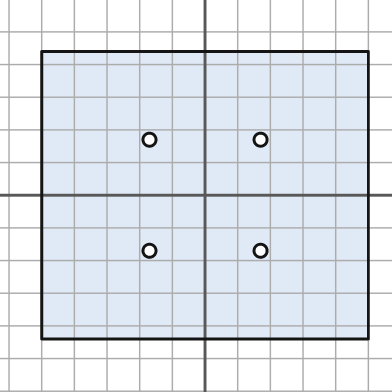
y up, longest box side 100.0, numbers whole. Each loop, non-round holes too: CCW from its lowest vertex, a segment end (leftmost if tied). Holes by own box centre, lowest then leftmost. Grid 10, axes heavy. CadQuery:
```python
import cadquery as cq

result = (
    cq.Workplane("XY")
    .moveTo(-50.0, -44.0)
    .lineTo(50.0, -44.0)
    .lineTo(50.0, 44.0)
    .lineTo(-50.0, 44.0)
    .close()
    .moveTo(-17.0, -17.0)
    .circle(2.0)
    .moveTo(17.0, -17.0)
    .circle(2.0)
    .moveTo(-17.0, 17.0)
    .circle(2.0)
    .moveTo(17.0, 17.0)
    .circle(2.0)
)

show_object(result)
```